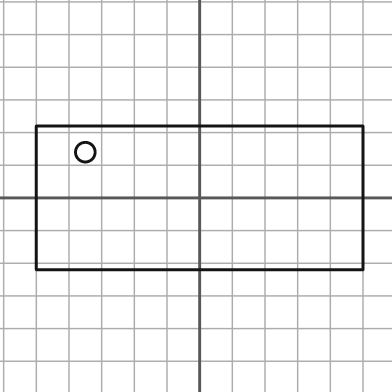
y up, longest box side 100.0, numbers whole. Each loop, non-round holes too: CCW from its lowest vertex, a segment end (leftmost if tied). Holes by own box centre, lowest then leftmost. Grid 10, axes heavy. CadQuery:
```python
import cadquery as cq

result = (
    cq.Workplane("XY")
    .moveTo(-50.0, -22.0)
    .lineTo(50.0, -22.0)
    .lineTo(50.0, 22.0)
    .lineTo(-50.0, 22.0)
    .close()
    .moveTo(-35.0, 14.0)
    .circle(3.0)
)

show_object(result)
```